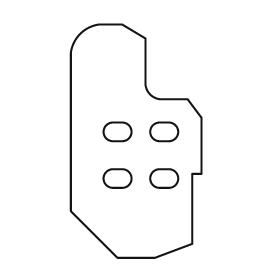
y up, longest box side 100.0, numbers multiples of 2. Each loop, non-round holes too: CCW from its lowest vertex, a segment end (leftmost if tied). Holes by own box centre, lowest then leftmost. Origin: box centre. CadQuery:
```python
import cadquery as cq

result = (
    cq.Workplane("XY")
    .moveTo(-8.0, -50.0)
    .lineTo(8.0, -50.0)
    .lineTo(24.0, -44.0)
    .lineTo(24.0, -14.0)
    .lineTo(28.0, -14.0)
    .lineTo(28.0, 10.0)
    .lineTo(22.0, 18.0)
    .lineTo(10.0, 18.0)
    .threePointArc((6.0, 20.0), (4.0, 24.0))
    .lineTo(4.0, 44.0)
    .lineTo(-6.0, 50.0)
    .lineTo(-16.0, 50.0)
    .threePointArc((-24.0, 46.0), (-28.0, 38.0))
    .lineTo(-28.0, -30.0)
    .close()
    .moveTo(-10.0, -20.0)
    .lineTo(-6.0, -20.0)
    .threePointArc((-2.0, -16.0), (-6.0, -12.0))
    .lineTo(-10.0, -12.0)
    .threePointArc((-14.0, -16.0), (-10.0, -20.0))
    .close()
    .moveTo(10.0, -20.0)
    .lineTo(14.0, -20.0)
    .threePointArc((18.0, -16.0), (14.0, -12.0))
    .lineTo(10.0, -12.0)
    .threePointArc((6.0, -16.0), (10.0, -20.0))
    .close()
    .moveTo(-10.0, 0.0)
    .lineTo(-6.0, 0.0)
    .threePointArc((-2.0, 4.0), (-6.0, 8.0))
    .lineTo(-10.0, 8.0)
    .threePointArc((-14.0, 4.0), (-10.0, 0.0))
    .close()
    .moveTo(10.0, 0.0)
    .lineTo(14.0, 0.0)
    .threePointArc((18.0, 4.0), (14.0, 8.0))
    .lineTo(10.0, 8.0)
    .threePointArc((6.0, 4.0), (10.0, 0.0))
    .close()
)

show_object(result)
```